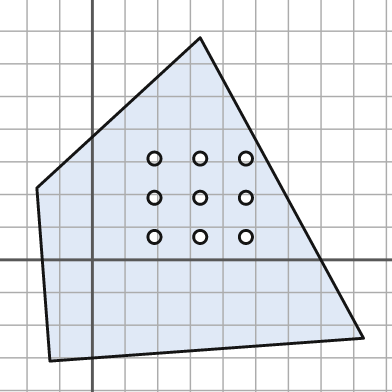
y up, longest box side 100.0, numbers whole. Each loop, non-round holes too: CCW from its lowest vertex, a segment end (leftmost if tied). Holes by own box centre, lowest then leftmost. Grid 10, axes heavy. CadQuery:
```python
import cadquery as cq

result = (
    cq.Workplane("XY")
    .moveTo(-13.0, -31.0)
    .lineTo(83.0, -24.0)
    .lineTo(33.0, 68.0)
    .lineTo(-17.0, 22.0)
    .close()
    .moveTo(19.0, 7.0)
    .circle(2.0)
    .moveTo(33.0, 7.0)
    .circle(2.0)
    .moveTo(47.0, 7.0)
    .circle(2.0)
    .moveTo(19.0, 19.0)
    .circle(2.0)
    .moveTo(33.0, 19.0)
    .circle(2.0)
    .moveTo(47.0, 19.0)
    .circle(2.0)
    .moveTo(19.0, 31.0)
    .circle(2.0)
    .moveTo(33.0, 31.0)
    .circle(2.0)
    .moveTo(47.0, 31.0)
    .circle(2.0)
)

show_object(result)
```